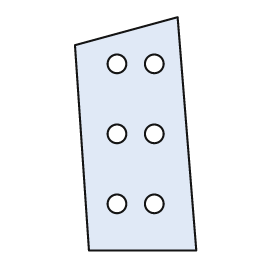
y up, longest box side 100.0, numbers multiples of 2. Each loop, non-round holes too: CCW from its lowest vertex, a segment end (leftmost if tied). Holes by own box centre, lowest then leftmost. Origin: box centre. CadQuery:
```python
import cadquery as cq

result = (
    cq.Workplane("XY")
    .moveTo(-20.0, -50.0)
    .lineTo(26.0, -50.0)
    .lineTo(18.0, 50.0)
    .lineTo(-26.0, 38.0)
    .close()
    .moveTo(-8.0, -30.0)
    .circle(4.0)
    .moveTo(8.0, -30.0)
    .circle(4.0)
    .moveTo(-8.0, 0.0)
    .circle(4.0)
    .moveTo(8.0, 0.0)
    .circle(4.0)
    .moveTo(-8.0, 30.0)
    .circle(4.0)
    .moveTo(8.0, 30.0)
    .circle(4.0)
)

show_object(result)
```